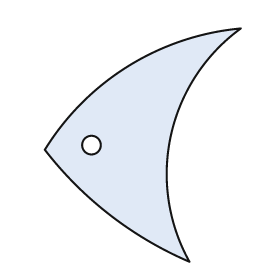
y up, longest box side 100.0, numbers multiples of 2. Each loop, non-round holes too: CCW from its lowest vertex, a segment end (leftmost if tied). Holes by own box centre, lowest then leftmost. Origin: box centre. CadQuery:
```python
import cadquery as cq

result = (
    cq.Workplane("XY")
    .moveTo(20.0, -50.0)
    .threePointArc((12.0, 4.0), (42.0, 50.0))
    .threePointArc((-6.0, 34.0), (-42.0, -2.0))
    .threePointArc((-14.0, -30.0), (20.0, -50.0))
    .close()
    .moveTo(-22.0, 0.0)
    .circle(4.0)
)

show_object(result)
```